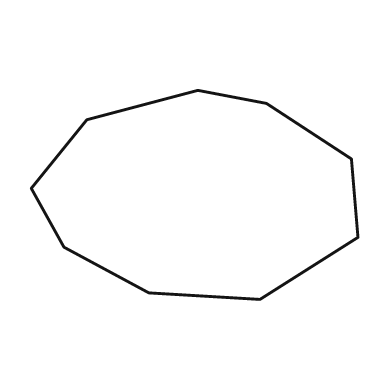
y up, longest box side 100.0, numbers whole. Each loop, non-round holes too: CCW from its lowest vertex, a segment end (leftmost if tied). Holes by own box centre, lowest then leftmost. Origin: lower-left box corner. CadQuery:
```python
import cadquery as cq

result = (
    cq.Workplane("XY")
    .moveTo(70.0, 0.0)
    .lineTo(100.0, 19.0)
    .lineTo(98.0, 43.0)
    .lineTo(72.0, 60.0)
    .lineTo(51.0, 64.0)
    .lineTo(17.0, 55.0)
    .lineTo(0.0, 34.0)
    .lineTo(10.0, 16.0)
    .lineTo(36.0, 2.0)
    .close()
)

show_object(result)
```